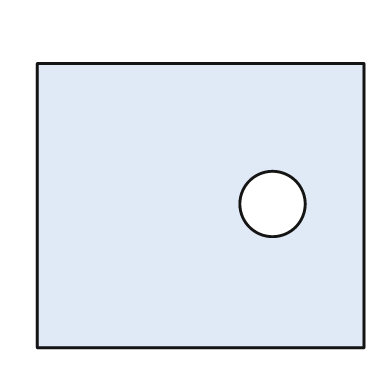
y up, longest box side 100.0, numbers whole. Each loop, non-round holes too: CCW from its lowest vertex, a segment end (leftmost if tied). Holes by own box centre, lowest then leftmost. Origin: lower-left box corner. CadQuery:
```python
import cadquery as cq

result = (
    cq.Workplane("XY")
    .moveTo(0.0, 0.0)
    .lineTo(100.0, 0.0)
    .lineTo(100.0, 87.0)
    .lineTo(0.0, 87.0)
    .close()
    .moveTo(72.0, 44.0)
    .circle(10.0)
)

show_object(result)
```